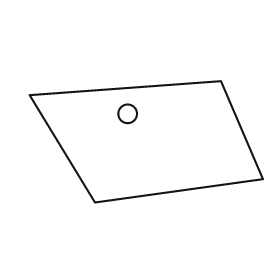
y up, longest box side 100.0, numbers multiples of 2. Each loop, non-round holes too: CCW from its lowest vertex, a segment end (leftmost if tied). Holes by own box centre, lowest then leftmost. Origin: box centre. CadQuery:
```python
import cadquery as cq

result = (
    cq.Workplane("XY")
    .moveTo(-22.0, -26.0)
    .lineTo(50.0, -16.0)
    .lineTo(32.0, 26.0)
    .lineTo(-50.0, 20.0)
    .close()
    .moveTo(-8.0, 12.0)
    .circle(4.0)
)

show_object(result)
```